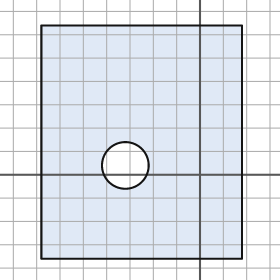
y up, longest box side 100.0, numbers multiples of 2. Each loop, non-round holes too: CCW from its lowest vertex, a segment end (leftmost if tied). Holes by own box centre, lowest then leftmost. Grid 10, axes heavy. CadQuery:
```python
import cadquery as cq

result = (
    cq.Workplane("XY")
    .moveTo(-68.0, -36.0)
    .lineTo(18.0, -36.0)
    .lineTo(18.0, 64.0)
    .lineTo(-68.0, 64.0)
    .close()
    .moveTo(-32.0, 4.0)
    .circle(10.0)
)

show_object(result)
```